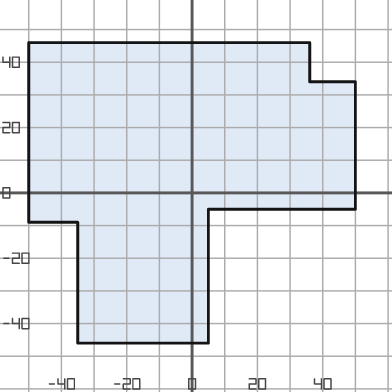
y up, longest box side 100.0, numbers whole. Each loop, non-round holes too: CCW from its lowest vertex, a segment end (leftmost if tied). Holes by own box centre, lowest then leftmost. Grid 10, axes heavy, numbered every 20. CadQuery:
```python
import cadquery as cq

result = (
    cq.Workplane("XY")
    .moveTo(-35.0, -46.0)
    .lineTo(5.0, -46.0)
    .lineTo(5.0, -5.0)
    .lineTo(50.0, -5.0)
    .lineTo(50.0, 34.0)
    .lineTo(36.0, 34.0)
    .lineTo(36.0, 46.0)
    .lineTo(-50.0, 46.0)
    .lineTo(-50.0, -9.0)
    .lineTo(-35.0, -9.0)
    .close()
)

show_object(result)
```